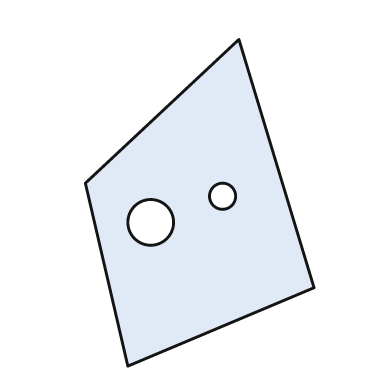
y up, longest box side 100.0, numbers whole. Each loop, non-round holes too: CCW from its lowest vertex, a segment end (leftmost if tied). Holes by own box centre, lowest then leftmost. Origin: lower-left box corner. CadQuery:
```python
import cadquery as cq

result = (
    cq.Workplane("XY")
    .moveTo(13.0, 0.0)
    .lineTo(70.0, 24.0)
    .lineTo(47.0, 100.0)
    .lineTo(0.0, 56.0)
    .close()
    .moveTo(20.0, 44.0)
    .circle(7.0)
    .moveTo(42.0, 52.0)
    .circle(4.0)
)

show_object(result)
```